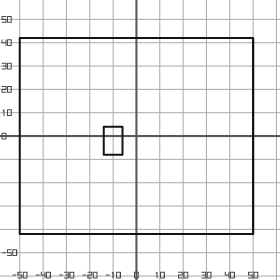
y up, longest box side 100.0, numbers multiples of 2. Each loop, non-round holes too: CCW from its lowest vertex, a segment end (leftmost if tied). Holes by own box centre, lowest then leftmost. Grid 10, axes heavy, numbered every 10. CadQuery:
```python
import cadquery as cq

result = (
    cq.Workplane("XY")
    .moveTo(-50.0, -42.0)
    .lineTo(50.0, -42.0)
    .lineTo(50.0, 42.0)
    .lineTo(-50.0, 42.0)
    .close()
    .moveTo(-14.0, -8.0)
    .lineTo(-6.0, -8.0)
    .lineTo(-6.0, 4.0)
    .lineTo(-14.0, 4.0)
    .close()
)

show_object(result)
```